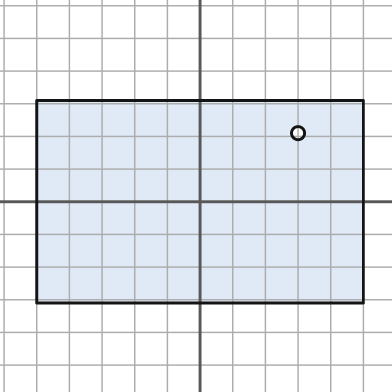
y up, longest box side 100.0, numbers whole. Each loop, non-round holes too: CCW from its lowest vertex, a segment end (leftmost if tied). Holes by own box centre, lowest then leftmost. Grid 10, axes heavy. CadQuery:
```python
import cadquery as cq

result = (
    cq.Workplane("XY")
    .moveTo(-50.0, -31.0)
    .lineTo(50.0, -31.0)
    .lineTo(50.0, 31.0)
    .lineTo(-50.0, 31.0)
    .close()
    .moveTo(30.0, 21.0)
    .circle(2.0)
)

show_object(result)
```